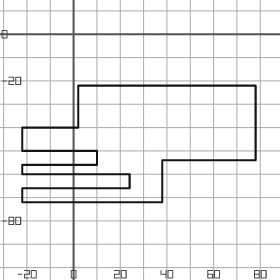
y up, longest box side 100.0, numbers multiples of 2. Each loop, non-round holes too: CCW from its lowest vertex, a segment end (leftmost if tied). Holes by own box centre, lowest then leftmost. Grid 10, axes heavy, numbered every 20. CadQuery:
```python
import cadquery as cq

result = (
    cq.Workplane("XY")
    .moveTo(-22.0, -72.0)
    .lineTo(38.0, -72.0)
    .lineTo(38.0, -54.0)
    .lineTo(78.0, -54.0)
    .lineTo(78.0, -22.0)
    .lineTo(2.0, -22.0)
    .lineTo(2.0, -40.0)
    .lineTo(-22.0, -40.0)
    .lineTo(-22.0, -50.0)
    .lineTo(10.0, -50.0)
    .lineTo(10.0, -56.0)
    .lineTo(-22.0, -56.0)
    .lineTo(-22.0, -60.0)
    .lineTo(24.0, -60.0)
    .lineTo(24.0, -66.0)
    .lineTo(-22.0, -66.0)
    .close()
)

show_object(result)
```